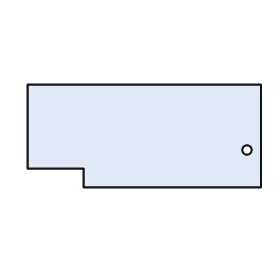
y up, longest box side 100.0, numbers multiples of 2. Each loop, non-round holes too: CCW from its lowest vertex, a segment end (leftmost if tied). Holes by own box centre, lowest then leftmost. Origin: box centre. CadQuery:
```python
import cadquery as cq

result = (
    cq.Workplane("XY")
    .moveTo(-26.0, -22.0)
    .lineTo(50.0, -22.0)
    .lineTo(50.0, 22.0)
    .lineTo(-50.0, 22.0)
    .lineTo(-50.0, -14.0)
    .lineTo(-26.0, -14.0)
    .close()
    .moveTo(44.0, -6.0)
    .circle(2.0)
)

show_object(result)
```